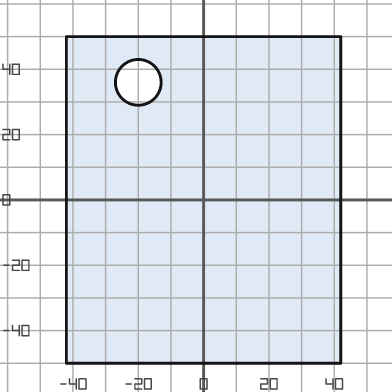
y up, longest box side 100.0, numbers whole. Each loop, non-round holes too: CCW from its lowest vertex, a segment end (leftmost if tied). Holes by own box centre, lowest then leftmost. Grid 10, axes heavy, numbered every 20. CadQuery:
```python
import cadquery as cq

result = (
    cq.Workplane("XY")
    .moveTo(-42.0, -50.0)
    .lineTo(42.0, -50.0)
    .lineTo(42.0, 50.0)
    .lineTo(-42.0, 50.0)
    .close()
    .moveTo(-20.0, 36.0)
    .circle(7.0)
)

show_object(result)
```